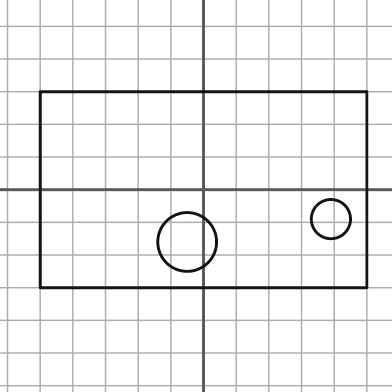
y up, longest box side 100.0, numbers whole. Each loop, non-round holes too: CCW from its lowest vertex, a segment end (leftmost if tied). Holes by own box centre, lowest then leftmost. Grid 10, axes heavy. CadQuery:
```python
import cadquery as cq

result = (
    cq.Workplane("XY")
    .moveTo(-50.0, -30.0)
    .lineTo(50.0, -30.0)
    .lineTo(50.0, 30.0)
    .lineTo(-50.0, 30.0)
    .close()
    .moveTo(-5.0, -16.0)
    .circle(9.0)
    .moveTo(39.0, -9.0)
    .circle(6.0)
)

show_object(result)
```